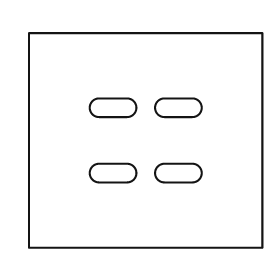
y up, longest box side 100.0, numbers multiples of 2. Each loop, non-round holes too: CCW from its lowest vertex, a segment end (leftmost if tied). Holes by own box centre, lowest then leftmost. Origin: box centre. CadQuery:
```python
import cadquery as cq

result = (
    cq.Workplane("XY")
    .moveTo(-50.0, -46.0)
    .lineTo(50.0, -46.0)
    .lineTo(50.0, 46.0)
    .lineTo(-50.0, 46.0)
    .close()
    .moveTo(-20.0, -18.0)
    .lineTo(-8.0, -18.0)
    .threePointArc((-4.0, -14.0), (-8.0, -10.0))
    .lineTo(-20.0, -10.0)
    .threePointArc((-24.0, -14.0), (-20.0, -18.0))
    .close()
    .moveTo(8.0, -18.0)
    .lineTo(20.0, -18.0)
    .threePointArc((24.0, -14.0), (20.0, -10.0))
    .lineTo(8.0, -10.0)
    .threePointArc((4.0, -14.0), (8.0, -18.0))
    .close()
    .moveTo(-20.0, 10.0)
    .lineTo(-8.0, 10.0)
    .threePointArc((-4.0, 14.0), (-8.0, 18.0))
    .lineTo(-20.0, 18.0)
    .threePointArc((-24.0, 14.0), (-20.0, 10.0))
    .close()
    .moveTo(8.0, 10.0)
    .lineTo(20.0, 10.0)
    .threePointArc((24.0, 14.0), (20.0, 18.0))
    .lineTo(8.0, 18.0)
    .threePointArc((4.0, 14.0), (8.0, 10.0))
    .close()
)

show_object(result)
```